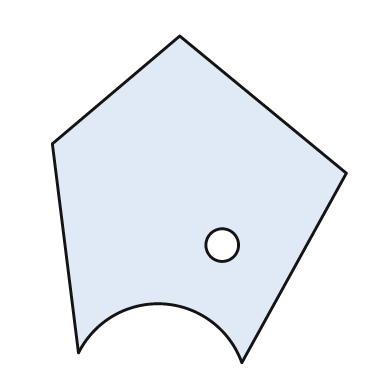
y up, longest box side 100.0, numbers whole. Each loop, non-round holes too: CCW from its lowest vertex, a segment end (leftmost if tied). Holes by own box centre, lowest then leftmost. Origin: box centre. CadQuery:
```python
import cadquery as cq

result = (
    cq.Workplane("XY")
    .moveTo(13.0, -50.0)
    .lineTo(45.0, 8.0)
    .lineTo(-6.0, 50.0)
    .lineTo(-45.0, 17.0)
    .lineTo(-37.0, -47.0)
    .threePointArc((-11.0, -32.0), (13.0, -50.0))
    .close()
    .moveTo(7.0, -14.0)
    .circle(5.0)
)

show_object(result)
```